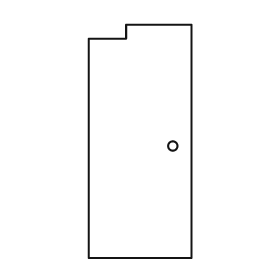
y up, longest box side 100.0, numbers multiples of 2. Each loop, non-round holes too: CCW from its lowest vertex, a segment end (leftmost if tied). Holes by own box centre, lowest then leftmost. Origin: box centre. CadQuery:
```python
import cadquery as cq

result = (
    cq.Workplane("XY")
    .moveTo(-22.0, -50.0)
    .lineTo(22.0, -50.0)
    .lineTo(22.0, 50.0)
    .lineTo(-6.0, 50.0)
    .lineTo(-6.0, 44.0)
    .lineTo(-22.0, 44.0)
    .close()
    .moveTo(14.0, -2.0)
    .circle(2.0)
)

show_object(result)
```